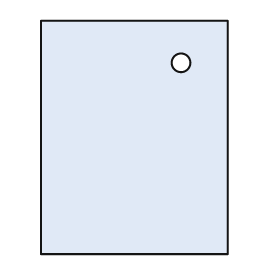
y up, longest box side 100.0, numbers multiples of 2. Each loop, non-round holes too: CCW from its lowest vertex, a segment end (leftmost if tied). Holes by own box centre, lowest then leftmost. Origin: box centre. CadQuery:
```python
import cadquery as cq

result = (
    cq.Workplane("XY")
    .moveTo(-40.0, -50.0)
    .lineTo(40.0, -50.0)
    .lineTo(40.0, 50.0)
    .lineTo(-40.0, 50.0)
    .close()
    .moveTo(20.0, 32.0)
    .circle(4.0)
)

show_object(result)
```